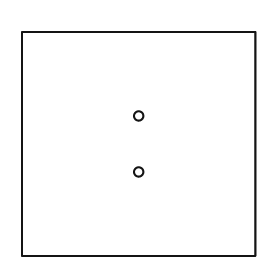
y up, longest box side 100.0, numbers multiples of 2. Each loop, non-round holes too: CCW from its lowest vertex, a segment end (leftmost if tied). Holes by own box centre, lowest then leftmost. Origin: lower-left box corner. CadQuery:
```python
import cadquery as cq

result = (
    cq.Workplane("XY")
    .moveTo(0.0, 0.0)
    .lineTo(100.0, 0.0)
    .lineTo(100.0, 96.0)
    .lineTo(0.0, 96.0)
    .close()
    .moveTo(50.0, 36.0)
    .circle(2.0)
    .moveTo(50.0, 60.0)
    .circle(2.0)
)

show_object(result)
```